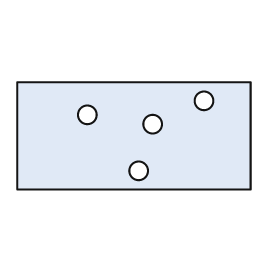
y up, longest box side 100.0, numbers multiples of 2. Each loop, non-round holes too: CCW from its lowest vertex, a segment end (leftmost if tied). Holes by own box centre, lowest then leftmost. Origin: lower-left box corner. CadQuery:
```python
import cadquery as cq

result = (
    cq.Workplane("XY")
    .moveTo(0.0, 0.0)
    .lineTo(100.0, 0.0)
    .lineTo(100.0, 46.0)
    .lineTo(0.0, 46.0)
    .close()
    .moveTo(52.0, 8.0)
    .circle(4.0)
    .moveTo(58.0, 28.0)
    .circle(4.0)
    .moveTo(30.0, 32.0)
    .circle(4.0)
    .moveTo(80.0, 38.0)
    .circle(4.0)
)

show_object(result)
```